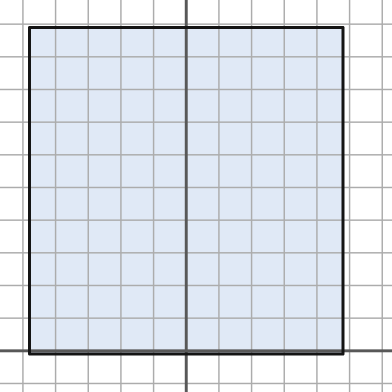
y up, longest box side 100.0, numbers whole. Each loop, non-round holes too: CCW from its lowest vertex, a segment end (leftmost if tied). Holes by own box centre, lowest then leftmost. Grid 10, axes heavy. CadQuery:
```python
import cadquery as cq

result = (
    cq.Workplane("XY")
    .moveTo(-48.0, -1.0)
    .lineTo(48.0, -1.0)
    .lineTo(48.0, 99.0)
    .lineTo(-48.0, 99.0)
    .close()
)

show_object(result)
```